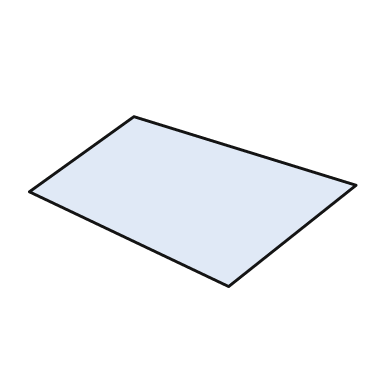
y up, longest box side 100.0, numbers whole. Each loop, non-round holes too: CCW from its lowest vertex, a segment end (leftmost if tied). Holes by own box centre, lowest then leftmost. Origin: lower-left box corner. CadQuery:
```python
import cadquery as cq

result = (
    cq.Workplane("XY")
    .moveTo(61.0, 0.0)
    .lineTo(100.0, 31.0)
    .lineTo(32.0, 52.0)
    .lineTo(0.0, 29.0)
    .close()
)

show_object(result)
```